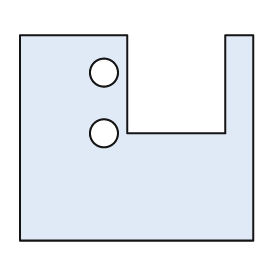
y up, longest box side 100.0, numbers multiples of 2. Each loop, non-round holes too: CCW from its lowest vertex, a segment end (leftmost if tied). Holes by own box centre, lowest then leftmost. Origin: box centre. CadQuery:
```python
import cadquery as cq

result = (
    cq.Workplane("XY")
    .moveTo(-50.0, -44.0)
    .lineTo(50.0, -44.0)
    .lineTo(50.0, 44.0)
    .lineTo(38.0, 44.0)
    .lineTo(38.0, 2.0)
    .lineTo(-4.0, 2.0)
    .lineTo(-4.0, 44.0)
    .lineTo(-50.0, 44.0)
    .close()
    .moveTo(-14.0, 2.0)
    .circle(6.0)
    .moveTo(-14.0, 28.0)
    .circle(6.0)
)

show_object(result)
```